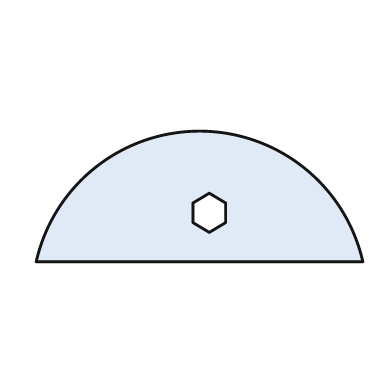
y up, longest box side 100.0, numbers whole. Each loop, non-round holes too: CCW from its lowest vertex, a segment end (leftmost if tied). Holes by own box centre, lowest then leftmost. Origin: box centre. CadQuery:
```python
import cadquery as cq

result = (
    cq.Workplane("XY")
    .moveTo(-50.0, -20.0)
    .lineTo(50.0, -20.0)
    .threePointArc((0.0, 20.0), (-50.0, -20.0))
    .close()
    .moveTo(3.0, -11.0)
    .lineTo(8.0, -8.0)
    .lineTo(8.0, -2.0)
    .lineTo(3.0, 1.0)
    .lineTo(-2.0, -2.0)
    .lineTo(-2.0, -8.0)
    .close()
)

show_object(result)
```